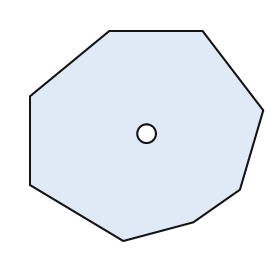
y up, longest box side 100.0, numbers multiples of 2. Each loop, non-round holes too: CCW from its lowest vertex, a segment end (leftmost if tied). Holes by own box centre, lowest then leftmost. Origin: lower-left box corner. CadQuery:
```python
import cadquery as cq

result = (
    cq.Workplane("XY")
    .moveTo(40.0, 0.0)
    .lineTo(70.0, 8.0)
    .lineTo(90.0, 22.0)
    .lineTo(100.0, 56.0)
    .lineTo(74.0, 90.0)
    .lineTo(34.0, 90.0)
    .lineTo(0.0, 62.0)
    .lineTo(0.0, 24.0)
    .close()
    .moveTo(50.0, 46.0)
    .circle(4.0)
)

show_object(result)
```